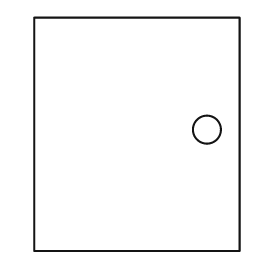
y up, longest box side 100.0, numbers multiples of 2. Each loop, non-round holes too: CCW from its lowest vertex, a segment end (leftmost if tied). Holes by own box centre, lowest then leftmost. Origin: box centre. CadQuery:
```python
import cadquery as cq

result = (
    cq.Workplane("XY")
    .moveTo(-44.0, -50.0)
    .lineTo(44.0, -50.0)
    .lineTo(44.0, 50.0)
    .lineTo(-44.0, 50.0)
    .close()
    .moveTo(30.0, 2.0)
    .circle(6.0)
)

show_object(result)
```